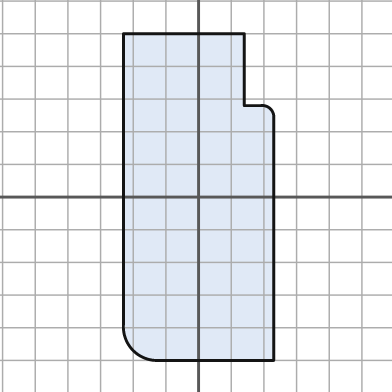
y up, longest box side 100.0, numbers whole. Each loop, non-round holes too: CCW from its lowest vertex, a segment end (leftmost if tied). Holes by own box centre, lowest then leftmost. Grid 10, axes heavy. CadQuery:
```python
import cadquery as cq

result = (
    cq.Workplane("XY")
    .moveTo(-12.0, -50.0)
    .lineTo(23.0, -50.0)
    .lineTo(23.0, 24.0)
    .threePointArc((22.0, 27.0), (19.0, 28.0))
    .lineTo(14.0, 28.0)
    .lineTo(14.0, 50.0)
    .lineTo(-23.0, 50.0)
    .lineTo(-23.0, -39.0)
    .threePointArc((-20.0, -47.0), (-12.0, -50.0))
    .close()
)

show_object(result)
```